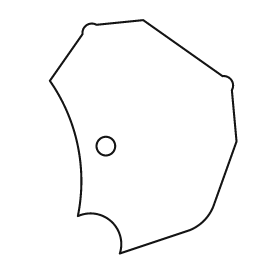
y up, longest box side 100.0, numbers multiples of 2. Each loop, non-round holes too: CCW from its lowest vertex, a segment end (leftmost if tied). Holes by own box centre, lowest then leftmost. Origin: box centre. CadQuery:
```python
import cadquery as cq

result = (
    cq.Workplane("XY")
    .moveTo(-10.0, -50.0)
    .lineTo(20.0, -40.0)
    .threePointArc((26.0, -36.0), (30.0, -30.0))
    .lineTo(40.0, -2.0)
    .lineTo(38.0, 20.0)
    .threePointArc((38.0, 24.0), (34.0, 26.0))
    .lineTo(0.0, 50.0)
    .lineTo(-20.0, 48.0)
    .threePointArc((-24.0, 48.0), (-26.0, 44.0))
    .lineTo(-40.0, 24.0)
    .threePointArc((-28.0, -4.0), (-28.0, -34.0))
    .threePointArc((-14.0, -36.0), (-10.0, -50.0))
    .close()
    .moveTo(-16.0, -4.0)
    .circle(4.0)
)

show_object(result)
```